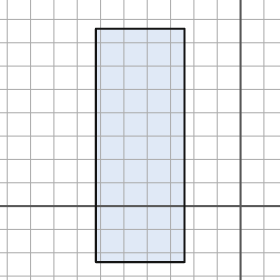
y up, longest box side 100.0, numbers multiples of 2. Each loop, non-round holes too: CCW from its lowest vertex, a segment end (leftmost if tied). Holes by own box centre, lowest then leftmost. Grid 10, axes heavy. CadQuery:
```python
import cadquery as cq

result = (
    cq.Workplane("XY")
    .moveTo(-62.0, -24.0)
    .lineTo(-24.0, -24.0)
    .lineTo(-24.0, 76.0)
    .lineTo(-62.0, 76.0)
    .close()
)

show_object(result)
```